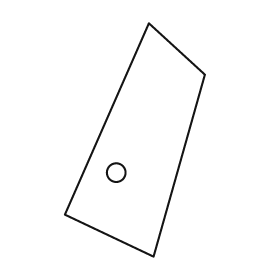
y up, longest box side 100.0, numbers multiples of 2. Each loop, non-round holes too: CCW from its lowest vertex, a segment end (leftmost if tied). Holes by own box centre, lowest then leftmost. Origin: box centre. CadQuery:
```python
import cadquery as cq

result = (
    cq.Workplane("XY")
    .moveTo(8.0, -50.0)
    .lineTo(30.0, 28.0)
    .lineTo(6.0, 50.0)
    .lineTo(-30.0, -32.0)
    .close()
    .moveTo(-8.0, -14.0)
    .circle(4.0)
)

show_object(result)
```